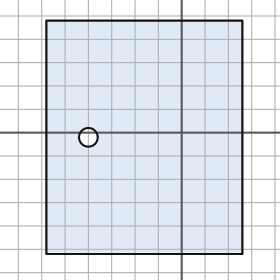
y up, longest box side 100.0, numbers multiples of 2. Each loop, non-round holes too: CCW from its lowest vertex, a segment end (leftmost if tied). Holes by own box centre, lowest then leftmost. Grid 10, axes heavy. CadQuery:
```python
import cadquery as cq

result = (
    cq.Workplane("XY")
    .moveTo(-58.0, -52.0)
    .lineTo(26.0, -52.0)
    .lineTo(26.0, 48.0)
    .lineTo(-58.0, 48.0)
    .close()
    .moveTo(-40.0, -2.0)
    .circle(4.0)
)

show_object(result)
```